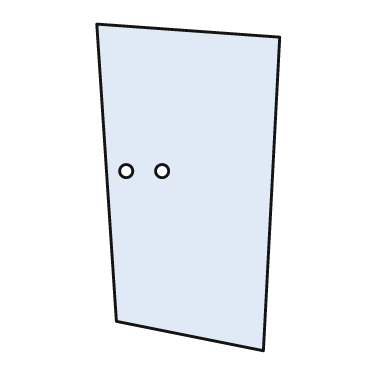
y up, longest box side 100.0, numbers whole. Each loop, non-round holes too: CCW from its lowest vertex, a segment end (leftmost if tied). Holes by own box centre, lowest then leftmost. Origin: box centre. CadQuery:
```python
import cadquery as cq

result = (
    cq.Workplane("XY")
    .moveTo(23.0, -50.0)
    .lineTo(28.0, 46.0)
    .lineTo(-28.0, 50.0)
    .lineTo(-22.0, -41.0)
    .close()
    .moveTo(-19.0, 5.0)
    .circle(2.0)
    .moveTo(-8.0, 5.0)
    .circle(2.0)
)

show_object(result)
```